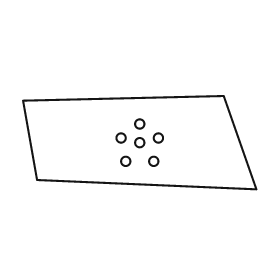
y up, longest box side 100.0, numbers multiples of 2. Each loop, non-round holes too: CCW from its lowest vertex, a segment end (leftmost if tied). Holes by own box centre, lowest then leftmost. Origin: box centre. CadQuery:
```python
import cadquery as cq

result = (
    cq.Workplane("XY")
    .moveTo(50.0, -20.0)
    .lineTo(36.0, 20.0)
    .lineTo(-50.0, 18.0)
    .lineTo(-44.0, -16.0)
    .close()
    .moveTo(-6.0, -8.0)
    .circle(2.0)
    .moveTo(6.0, -8.0)
    .circle(2.0)
    .moveTo(0.0, 0.0)
    .circle(2.0)
    .moveTo(-8.0, 2.0)
    .circle(2.0)
    .moveTo(8.0, 2.0)
    .circle(2.0)
    .moveTo(0.0, 8.0)
    .circle(2.0)
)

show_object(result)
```